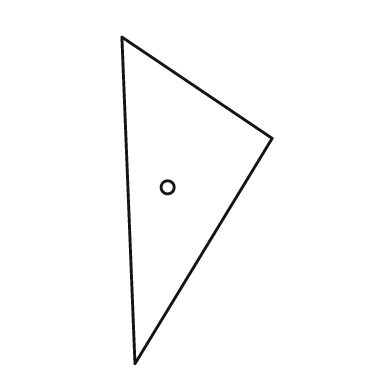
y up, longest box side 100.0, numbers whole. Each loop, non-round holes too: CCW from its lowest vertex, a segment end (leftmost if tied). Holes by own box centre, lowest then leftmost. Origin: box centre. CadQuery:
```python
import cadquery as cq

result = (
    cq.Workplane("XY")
    .moveTo(-19.0, -50.0)
    .lineTo(23.0, 19.0)
    .lineTo(-23.0, 50.0)
    .close()
    .moveTo(-9.0, 4.0)
    .circle(2.0)
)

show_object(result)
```